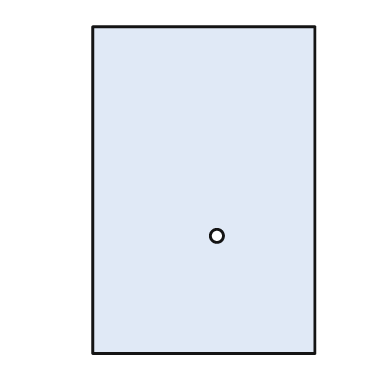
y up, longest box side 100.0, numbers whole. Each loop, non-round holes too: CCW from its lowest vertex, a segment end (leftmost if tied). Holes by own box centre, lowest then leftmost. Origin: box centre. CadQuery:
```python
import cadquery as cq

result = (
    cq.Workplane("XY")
    .moveTo(-34.0, -50.0)
    .lineTo(34.0, -50.0)
    .lineTo(34.0, 50.0)
    .lineTo(-34.0, 50.0)
    .close()
    .moveTo(4.0, -14.0)
    .circle(2.0)
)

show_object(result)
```